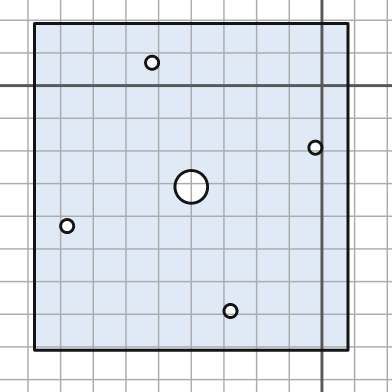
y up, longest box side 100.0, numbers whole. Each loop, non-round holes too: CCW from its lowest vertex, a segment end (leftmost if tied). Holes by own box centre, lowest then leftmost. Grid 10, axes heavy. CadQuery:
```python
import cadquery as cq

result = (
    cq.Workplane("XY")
    .moveTo(-88.0, -81.0)
    .lineTo(8.0, -81.0)
    .lineTo(8.0, 19.0)
    .lineTo(-88.0, 19.0)
    .close()
    .moveTo(-28.0, -69.0)
    .circle(2.0)
    .moveTo(-78.0, -43.0)
    .circle(2.0)
    .moveTo(-40.0, -31.0)
    .circle(5.0)
    .moveTo(-2.0, -19.0)
    .circle(2.0)
    .moveTo(-52.0, 7.0)
    .circle(2.0)
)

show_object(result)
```